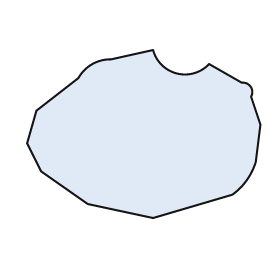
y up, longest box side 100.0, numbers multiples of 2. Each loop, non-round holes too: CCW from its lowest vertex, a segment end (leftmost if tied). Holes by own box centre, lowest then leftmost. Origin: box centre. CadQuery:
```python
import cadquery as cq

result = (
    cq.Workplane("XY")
    .moveTo(4.0, -36.0)
    .lineTo(38.0, -26.0)
    .threePointArc((44.0, -20.0), (48.0, -12.0))
    .lineTo(50.0, 4.0)
    .lineTo(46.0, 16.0)
    .threePointArc((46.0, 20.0), (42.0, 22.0))
    .lineTo(28.0, 30.0)
    .threePointArc((14.0, 26.0), (4.0, 36.0))
    .lineTo(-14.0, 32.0)
    .threePointArc((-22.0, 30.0), (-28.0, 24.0))
    .lineTo(-46.0, 10.0)
    .lineTo(-50.0, -4.0)
    .lineTo(-44.0, -16.0)
    .lineTo(-24.0, -30.0)
    .close()
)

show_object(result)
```